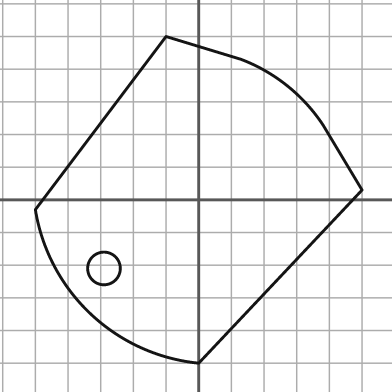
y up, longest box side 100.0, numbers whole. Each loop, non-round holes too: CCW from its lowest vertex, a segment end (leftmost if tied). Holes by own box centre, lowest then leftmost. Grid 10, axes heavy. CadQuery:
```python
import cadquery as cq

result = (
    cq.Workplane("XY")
    .moveTo(0.0, -50.0)
    .lineTo(50.0, 3.0)
    .lineTo(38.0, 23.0)
    .threePointArc((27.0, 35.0), (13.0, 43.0))
    .lineTo(-10.0, 50.0)
    .lineTo(-50.0, -3.0)
    .threePointArc((-33.0, -35.0), (0.0, -50.0))
    .close()
    .moveTo(-29.0, -21.0)
    .circle(5.0)
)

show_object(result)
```